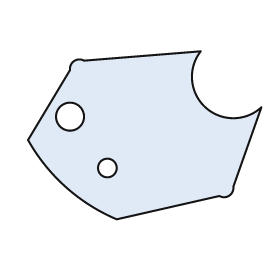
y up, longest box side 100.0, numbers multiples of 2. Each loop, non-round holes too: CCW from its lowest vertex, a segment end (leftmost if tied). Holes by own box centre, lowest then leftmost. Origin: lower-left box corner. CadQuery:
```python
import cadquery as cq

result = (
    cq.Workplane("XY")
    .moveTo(38.0, 0.0)
    .lineTo(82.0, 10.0)
    .threePointArc((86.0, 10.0), (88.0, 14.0))
    .lineTo(100.0, 48.0)
    .threePointArc((76.0, 48.0), (74.0, 72.0))
    .lineTo(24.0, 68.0)
    .threePointArc((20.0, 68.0), (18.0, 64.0))
    .lineTo(0.0, 34.0)
    .threePointArc((16.0, 14.0), (38.0, 0.0))
    .close()
    .moveTo(34.0, 22.0)
    .circle(4.0)
    .moveTo(18.0, 44.0)
    .circle(6.0)
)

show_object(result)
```